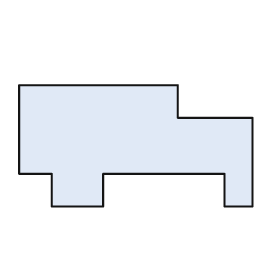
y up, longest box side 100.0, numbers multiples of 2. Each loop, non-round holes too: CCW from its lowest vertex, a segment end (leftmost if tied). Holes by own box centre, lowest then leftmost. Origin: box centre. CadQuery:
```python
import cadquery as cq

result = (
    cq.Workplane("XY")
    .moveTo(-36.0, -26.0)
    .lineTo(-14.0, -26.0)
    .lineTo(-14.0, -12.0)
    .lineTo(38.0, -12.0)
    .lineTo(38.0, -26.0)
    .lineTo(50.0, -26.0)
    .lineTo(50.0, 12.0)
    .lineTo(18.0, 12.0)
    .lineTo(18.0, 26.0)
    .lineTo(-50.0, 26.0)
    .lineTo(-50.0, -12.0)
    .lineTo(-36.0, -12.0)
    .close()
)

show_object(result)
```